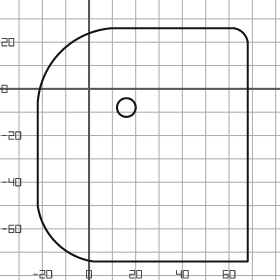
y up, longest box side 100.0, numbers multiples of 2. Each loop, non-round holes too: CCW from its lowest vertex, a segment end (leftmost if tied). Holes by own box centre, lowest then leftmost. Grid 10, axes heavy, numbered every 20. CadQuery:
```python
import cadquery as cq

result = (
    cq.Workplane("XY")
    .moveTo(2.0, -74.0)
    .lineTo(68.0, -74.0)
    .lineTo(68.0, 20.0)
    .threePointArc((66.0, 24.0), (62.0, 26.0))
    .lineTo(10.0, 26.0)
    .threePointArc((-12.0, 16.0), (-22.0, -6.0))
    .lineTo(-22.0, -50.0)
    .threePointArc((-14.0, -66.0), (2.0, -74.0))
    .close()
    .moveTo(16.0, -8.0)
    .circle(4.0)
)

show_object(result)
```